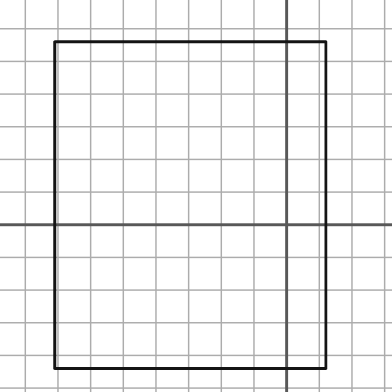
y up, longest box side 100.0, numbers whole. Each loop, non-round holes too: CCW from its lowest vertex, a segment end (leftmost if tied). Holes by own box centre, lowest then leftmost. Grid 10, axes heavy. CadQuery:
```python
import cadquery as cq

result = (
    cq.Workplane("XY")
    .moveTo(-71.0, -44.0)
    .lineTo(12.0, -44.0)
    .lineTo(12.0, 56.0)
    .lineTo(-71.0, 56.0)
    .close()
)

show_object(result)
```